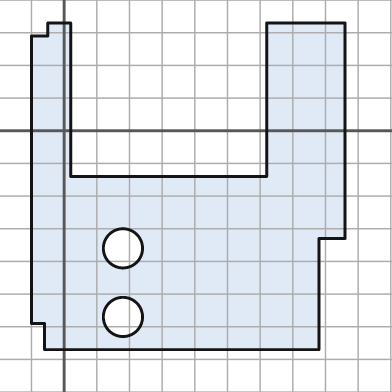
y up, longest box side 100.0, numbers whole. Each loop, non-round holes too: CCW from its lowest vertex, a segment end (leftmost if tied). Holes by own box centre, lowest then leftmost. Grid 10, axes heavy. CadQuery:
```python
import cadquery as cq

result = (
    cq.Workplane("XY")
    .moveTo(-6.0, -67.0)
    .lineTo(78.0, -67.0)
    .lineTo(78.0, -33.0)
    .lineTo(86.0, -33.0)
    .lineTo(86.0, 33.0)
    .lineTo(62.0, 33.0)
    .lineTo(62.0, -14.0)
    .lineTo(2.0, -14.0)
    .lineTo(2.0, 33.0)
    .lineTo(-5.0, 33.0)
    .lineTo(-5.0, 29.0)
    .lineTo(-10.0, 29.0)
    .lineTo(-10.0, -59.0)
    .lineTo(-6.0, -59.0)
    .close()
    .moveTo(18.0, -57.0)
    .circle(6.0)
    .moveTo(18.0, -36.0)
    .circle(6.0)
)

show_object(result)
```